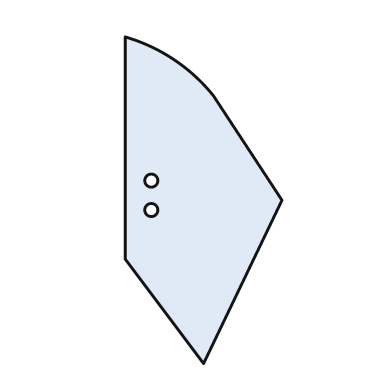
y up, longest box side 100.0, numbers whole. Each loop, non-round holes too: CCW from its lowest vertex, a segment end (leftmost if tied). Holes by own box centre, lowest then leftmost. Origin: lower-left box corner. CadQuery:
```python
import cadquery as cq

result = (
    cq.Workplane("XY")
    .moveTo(24.0, 0.0)
    .lineTo(48.0, 50.0)
    .lineTo(27.0, 82.0)
    .threePointArc((15.0, 93.0), (0.0, 100.0))
    .lineTo(0.0, 32.0)
    .close()
    .moveTo(8.0, 47.0)
    .circle(2.0)
    .moveTo(8.0, 56.0)
    .circle(2.0)
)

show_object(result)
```